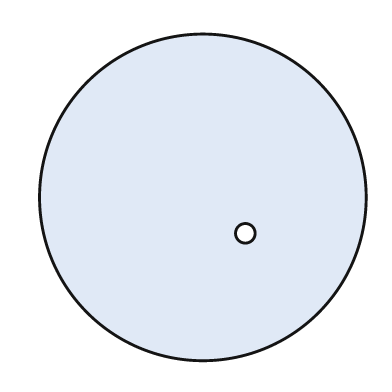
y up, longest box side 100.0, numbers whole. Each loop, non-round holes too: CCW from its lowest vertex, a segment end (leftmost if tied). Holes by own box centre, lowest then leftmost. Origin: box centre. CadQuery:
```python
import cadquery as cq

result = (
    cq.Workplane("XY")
    .moveTo(0.0, 0.0)
    .circle(50.0)
    .moveTo(13.0, -11.0)
    .circle(3.0)
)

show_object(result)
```